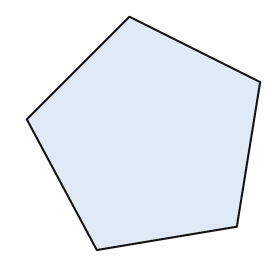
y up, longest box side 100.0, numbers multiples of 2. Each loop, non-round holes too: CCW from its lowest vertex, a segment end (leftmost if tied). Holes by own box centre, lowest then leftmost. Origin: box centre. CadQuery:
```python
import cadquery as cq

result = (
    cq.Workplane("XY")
    .moveTo(-20.0, -50.0)
    .lineTo(40.0, -40.0)
    .lineTo(50.0, 22.0)
    .lineTo(-6.0, 50.0)
    .lineTo(-50.0, 6.0)
    .close()
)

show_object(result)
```